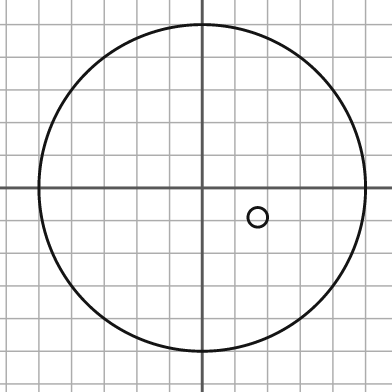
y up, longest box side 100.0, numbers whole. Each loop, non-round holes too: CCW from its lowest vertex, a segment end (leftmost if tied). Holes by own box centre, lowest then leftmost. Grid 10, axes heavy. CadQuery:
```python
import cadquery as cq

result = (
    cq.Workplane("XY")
    .moveTo(0.0, 0.0)
    .circle(50.0)
    .moveTo(17.0, -9.0)
    .circle(3.0)
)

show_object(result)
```